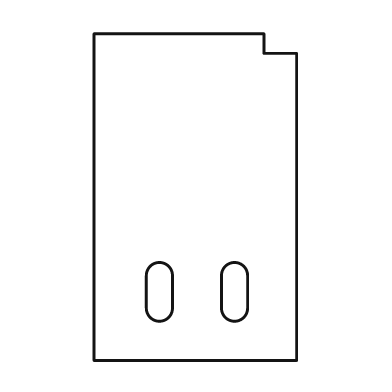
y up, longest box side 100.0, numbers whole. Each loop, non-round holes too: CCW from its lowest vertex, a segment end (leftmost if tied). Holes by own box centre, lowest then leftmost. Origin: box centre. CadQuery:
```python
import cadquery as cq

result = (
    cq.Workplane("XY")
    .moveTo(-31.0, -50.0)
    .lineTo(31.0, -50.0)
    .lineTo(31.0, 44.0)
    .lineTo(21.0, 44.0)
    .lineTo(21.0, 50.0)
    .lineTo(-31.0, 50.0)
    .close()
    .moveTo(-15.0, -34.0)
    .threePointArc((-11.0, -38.0), (-7.0, -34.0))
    .lineTo(-7.0, -24.0)
    .threePointArc((-11.0, -20.0), (-15.0, -24.0))
    .close()
    .moveTo(8.0, -34.0)
    .threePointArc((12.0, -38.0), (16.0, -34.0))
    .lineTo(16.0, -24.0)
    .threePointArc((12.0, -20.0), (8.0, -24.0))
    .close()
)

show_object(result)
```